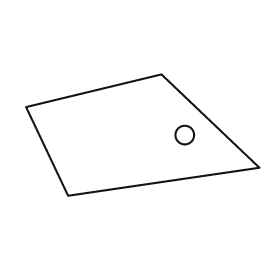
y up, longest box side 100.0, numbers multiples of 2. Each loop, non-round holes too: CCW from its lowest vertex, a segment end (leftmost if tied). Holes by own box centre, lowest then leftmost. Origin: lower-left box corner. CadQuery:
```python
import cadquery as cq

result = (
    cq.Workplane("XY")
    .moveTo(18.0, 0.0)
    .lineTo(100.0, 12.0)
    .lineTo(58.0, 52.0)
    .lineTo(0.0, 38.0)
    .close()
    .moveTo(68.0, 26.0)
    .circle(4.0)
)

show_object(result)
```